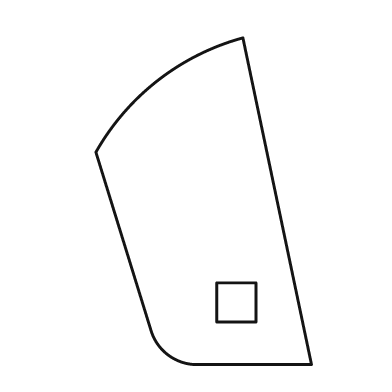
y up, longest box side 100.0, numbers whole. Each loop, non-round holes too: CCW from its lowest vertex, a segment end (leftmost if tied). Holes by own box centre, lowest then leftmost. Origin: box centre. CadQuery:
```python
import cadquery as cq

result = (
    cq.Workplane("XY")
    .moveTo(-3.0, -50.0)
    .lineTo(33.0, -50.0)
    .lineTo(12.0, 50.0)
    .threePointArc((-14.0, 37.0), (-33.0, 15.0))
    .lineTo(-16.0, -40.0)
    .threePointArc((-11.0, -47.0), (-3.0, -50.0))
    .close()
    .moveTo(4.0, -37.0)
    .lineTo(16.0, -37.0)
    .lineTo(16.0, -25.0)
    .lineTo(4.0, -25.0)
    .close()
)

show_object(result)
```